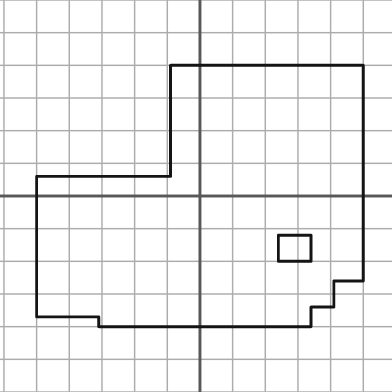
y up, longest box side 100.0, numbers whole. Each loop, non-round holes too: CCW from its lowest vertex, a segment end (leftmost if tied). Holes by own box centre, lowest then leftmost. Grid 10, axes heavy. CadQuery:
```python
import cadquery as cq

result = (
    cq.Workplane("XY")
    .moveTo(-31.0, -40.0)
    .lineTo(34.0, -40.0)
    .lineTo(34.0, -34.0)
    .lineTo(41.0, -34.0)
    .lineTo(41.0, -26.0)
    .lineTo(50.0, -26.0)
    .lineTo(50.0, 40.0)
    .lineTo(-9.0, 40.0)
    .lineTo(-9.0, 6.0)
    .lineTo(-50.0, 6.0)
    .lineTo(-50.0, -37.0)
    .lineTo(-31.0, -37.0)
    .close()
    .moveTo(24.0, -20.0)
    .lineTo(34.0, -20.0)
    .lineTo(34.0, -12.0)
    .lineTo(24.0, -12.0)
    .close()
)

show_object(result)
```